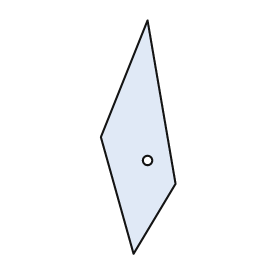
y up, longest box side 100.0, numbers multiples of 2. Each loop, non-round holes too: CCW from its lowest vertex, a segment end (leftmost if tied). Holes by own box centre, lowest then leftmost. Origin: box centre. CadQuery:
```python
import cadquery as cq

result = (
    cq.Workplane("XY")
    .moveTo(-2.0, -50.0)
    .lineTo(16.0, -20.0)
    .lineTo(4.0, 50.0)
    .lineTo(-16.0, 0.0)
    .close()
    .moveTo(4.0, -10.0)
    .circle(2.0)
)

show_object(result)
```